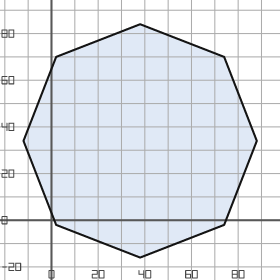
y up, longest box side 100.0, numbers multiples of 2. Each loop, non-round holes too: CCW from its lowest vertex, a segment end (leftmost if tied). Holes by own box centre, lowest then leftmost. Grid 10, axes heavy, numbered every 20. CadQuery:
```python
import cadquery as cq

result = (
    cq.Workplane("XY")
    .moveTo(38.0, -16.0)
    .lineTo(74.0, -2.0)
    .lineTo(88.0, 34.0)
    .lineTo(74.0, 70.0)
    .lineTo(38.0, 84.0)
    .lineTo(2.0, 70.0)
    .lineTo(-12.0, 34.0)
    .lineTo(2.0, -2.0)
    .close()
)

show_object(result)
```